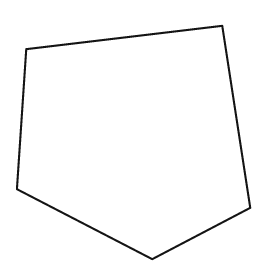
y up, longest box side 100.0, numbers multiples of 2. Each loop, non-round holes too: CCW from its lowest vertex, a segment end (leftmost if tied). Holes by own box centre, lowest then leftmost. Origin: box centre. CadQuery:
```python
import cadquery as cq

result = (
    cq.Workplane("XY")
    .moveTo(8.0, -50.0)
    .lineTo(50.0, -28.0)
    .lineTo(38.0, 50.0)
    .lineTo(-46.0, 40.0)
    .lineTo(-50.0, -20.0)
    .close()
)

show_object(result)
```